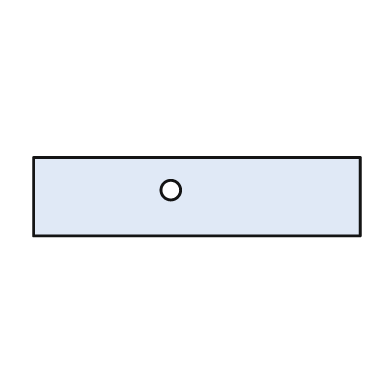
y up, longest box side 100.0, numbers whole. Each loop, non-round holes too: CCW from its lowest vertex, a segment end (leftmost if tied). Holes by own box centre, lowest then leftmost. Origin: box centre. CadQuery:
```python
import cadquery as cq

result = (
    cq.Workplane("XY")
    .moveTo(-50.0, -12.0)
    .lineTo(50.0, -12.0)
    .lineTo(50.0, 12.0)
    .lineTo(-50.0, 12.0)
    .close()
    .moveTo(-8.0, 2.0)
    .circle(3.0)
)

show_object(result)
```